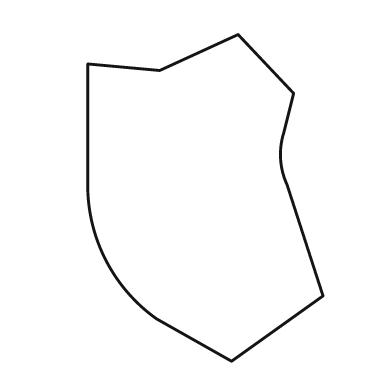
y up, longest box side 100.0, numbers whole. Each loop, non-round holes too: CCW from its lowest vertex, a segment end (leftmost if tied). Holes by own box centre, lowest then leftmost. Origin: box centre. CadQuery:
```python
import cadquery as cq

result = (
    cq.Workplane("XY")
    .moveTo(8.0, -50.0)
    .lineTo(36.0, -30.0)
    .lineTo(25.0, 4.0)
    .threePointArc((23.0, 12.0), (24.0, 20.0))
    .lineTo(27.0, 32.0)
    .lineTo(10.0, 50.0)
    .lineTo(-14.0, 39.0)
    .lineTo(-36.0, 41.0)
    .lineTo(-36.0, 2.0)
    .threePointArc((-30.0, -20.0), (-15.0, -37.0))
    .close()
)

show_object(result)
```